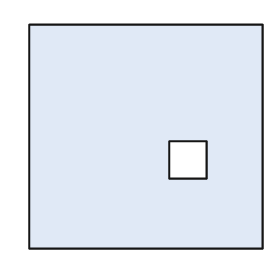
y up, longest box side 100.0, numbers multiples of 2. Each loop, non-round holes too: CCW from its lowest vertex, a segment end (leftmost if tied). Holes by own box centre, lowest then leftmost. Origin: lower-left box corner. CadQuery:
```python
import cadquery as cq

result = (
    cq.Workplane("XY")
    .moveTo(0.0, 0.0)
    .lineTo(100.0, 0.0)
    .lineTo(100.0, 96.0)
    .lineTo(0.0, 96.0)
    .close()
    .moveTo(60.0, 30.0)
    .lineTo(76.0, 30.0)
    .lineTo(76.0, 46.0)
    .lineTo(60.0, 46.0)
    .close()
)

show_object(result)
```